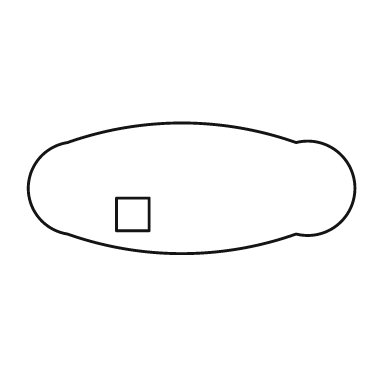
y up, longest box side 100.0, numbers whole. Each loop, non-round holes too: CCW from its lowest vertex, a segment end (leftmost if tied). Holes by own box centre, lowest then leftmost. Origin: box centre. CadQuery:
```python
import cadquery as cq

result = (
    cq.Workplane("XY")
    .moveTo(-38.0, -14.0)
    .threePointArc((-3.0, -20.0), (32.0, -14.0))
    .threePointArc((50.0, 0.0), (32.0, 14.0))
    .threePointArc((-3.0, 20.0), (-38.0, 14.0))
    .threePointArc((-50.0, 0.0), (-38.0, -14.0))
    .close()
    .moveTo(-23.0, -13.0)
    .lineTo(-13.0, -13.0)
    .lineTo(-13.0, -3.0)
    .lineTo(-23.0, -3.0)
    .close()
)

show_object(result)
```